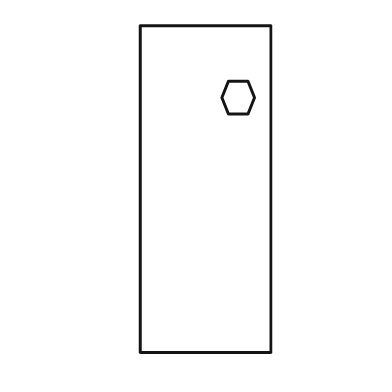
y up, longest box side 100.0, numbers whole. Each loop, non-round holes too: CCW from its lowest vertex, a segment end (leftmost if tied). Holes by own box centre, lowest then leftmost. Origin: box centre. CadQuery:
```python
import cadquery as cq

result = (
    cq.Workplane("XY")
    .moveTo(-20.0, -50.0)
    .lineTo(20.0, -50.0)
    .lineTo(20.0, 50.0)
    .lineTo(-20.0, 50.0)
    .close()
    .moveTo(7.0, 23.0)
    .lineTo(13.0, 23.0)
    .lineTo(15.0, 28.0)
    .lineTo(13.0, 33.0)
    .lineTo(7.0, 33.0)
    .lineTo(5.0, 28.0)
    .close()
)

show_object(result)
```